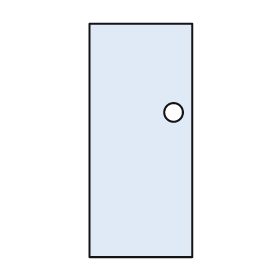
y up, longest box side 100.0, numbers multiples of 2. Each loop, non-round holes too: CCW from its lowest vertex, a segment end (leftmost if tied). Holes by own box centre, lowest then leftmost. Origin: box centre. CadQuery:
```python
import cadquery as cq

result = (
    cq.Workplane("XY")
    .moveTo(-22.0, -50.0)
    .lineTo(22.0, -50.0)
    .lineTo(22.0, 50.0)
    .lineTo(-22.0, 50.0)
    .close()
    .moveTo(14.0, 12.0)
    .circle(4.0)
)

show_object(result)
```